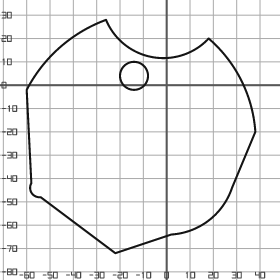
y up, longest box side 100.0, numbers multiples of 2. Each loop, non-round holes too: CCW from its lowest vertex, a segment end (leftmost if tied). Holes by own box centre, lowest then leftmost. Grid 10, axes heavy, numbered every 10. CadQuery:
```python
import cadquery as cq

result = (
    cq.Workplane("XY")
    .moveTo(-22.0, -72.0)
    .lineTo(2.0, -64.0)
    .threePointArc((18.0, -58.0), (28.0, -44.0))
    .lineTo(38.0, -20.0)
    .threePointArc((32.0, 2.0), (18.0, 20.0))
    .threePointArc((-6.0, 12.0), (-26.0, 28.0))
    .threePointArc((-46.0, 16.0), (-60.0, -2.0))
    .lineTo(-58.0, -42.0)
    .threePointArc((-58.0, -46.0), (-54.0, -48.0))
    .close()
    .moveTo(-14.0, 4.0)
    .circle(6.0)
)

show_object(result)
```